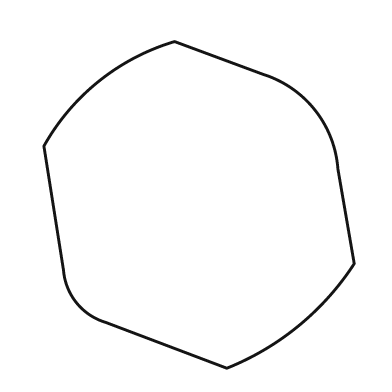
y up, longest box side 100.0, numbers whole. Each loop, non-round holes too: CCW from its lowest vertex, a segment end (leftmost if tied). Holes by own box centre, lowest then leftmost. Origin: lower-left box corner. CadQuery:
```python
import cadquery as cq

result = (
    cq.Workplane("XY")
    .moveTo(56.0, 0.0)
    .threePointArc((78.0, 13.0), (95.0, 32.0))
    .lineTo(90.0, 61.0)
    .threePointArc((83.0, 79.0), (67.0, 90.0))
    .lineTo(40.0, 100.0)
    .threePointArc((17.0, 88.0), (0.0, 68.0))
    .lineTo(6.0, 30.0)
    .threePointArc((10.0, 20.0), (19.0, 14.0))
    .close()
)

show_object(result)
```